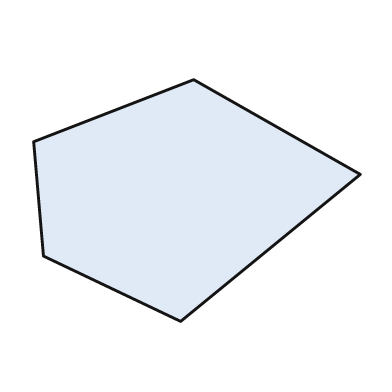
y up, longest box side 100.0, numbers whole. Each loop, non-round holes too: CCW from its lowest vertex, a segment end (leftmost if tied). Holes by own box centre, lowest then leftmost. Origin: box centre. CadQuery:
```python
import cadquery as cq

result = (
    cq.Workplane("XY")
    .moveTo(-5.0, -37.0)
    .lineTo(50.0, 8.0)
    .lineTo(-1.0, 37.0)
    .lineTo(-50.0, 18.0)
    .lineTo(-47.0, -17.0)
    .close()
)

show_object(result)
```